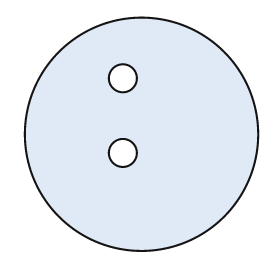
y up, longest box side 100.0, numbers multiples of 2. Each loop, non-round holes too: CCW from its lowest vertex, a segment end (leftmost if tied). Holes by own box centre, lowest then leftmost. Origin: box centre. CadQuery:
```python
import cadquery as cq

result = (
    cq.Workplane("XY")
    .moveTo(0.0, 0.0)
    .circle(50.0)
    .moveTo(-8.0, -8.0)
    .circle(6.0)
    .moveTo(-8.0, 24.0)
    .circle(6.0)
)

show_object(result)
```